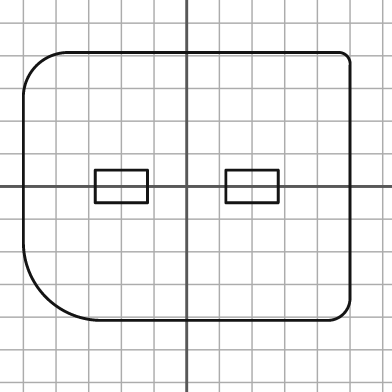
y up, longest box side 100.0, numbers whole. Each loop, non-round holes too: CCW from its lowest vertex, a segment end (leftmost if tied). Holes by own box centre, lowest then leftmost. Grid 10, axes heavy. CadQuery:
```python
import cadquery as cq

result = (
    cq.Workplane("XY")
    .moveTo(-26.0, -41.0)
    .lineTo(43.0, -41.0)
    .threePointArc((48.0, -39.0), (50.0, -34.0))
    .lineTo(50.0, 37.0)
    .threePointArc((49.0, 40.0), (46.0, 41.0))
    .lineTo(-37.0, 41.0)
    .threePointArc((-46.0, 37.0), (-50.0, 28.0))
    .lineTo(-50.0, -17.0)
    .threePointArc((-43.0, -34.0), (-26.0, -41.0))
    .close()
    .moveTo(-28.0, -5.0)
    .lineTo(-12.0, -5.0)
    .lineTo(-12.0, 5.0)
    .lineTo(-28.0, 5.0)
    .close()
    .moveTo(12.0, -5.0)
    .lineTo(28.0, -5.0)
    .lineTo(28.0, 5.0)
    .lineTo(12.0, 5.0)
    .close()
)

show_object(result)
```